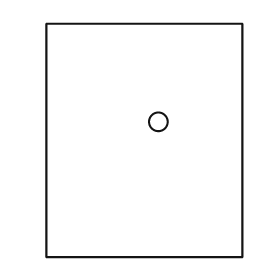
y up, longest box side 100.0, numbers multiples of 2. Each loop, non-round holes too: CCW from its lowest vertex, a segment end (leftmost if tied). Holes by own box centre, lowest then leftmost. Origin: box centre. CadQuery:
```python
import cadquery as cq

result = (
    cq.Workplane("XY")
    .moveTo(-42.0, -50.0)
    .lineTo(42.0, -50.0)
    .lineTo(42.0, 50.0)
    .lineTo(-42.0, 50.0)
    .close()
    .moveTo(6.0, 8.0)
    .circle(4.0)
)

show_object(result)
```